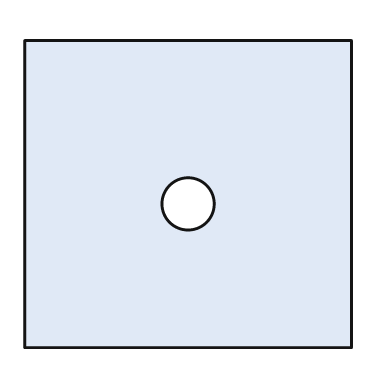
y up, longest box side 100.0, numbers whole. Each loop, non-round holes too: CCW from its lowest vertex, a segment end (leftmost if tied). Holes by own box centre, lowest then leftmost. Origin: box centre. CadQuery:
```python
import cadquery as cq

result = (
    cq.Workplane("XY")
    .moveTo(-50.0, -47.0)
    .lineTo(50.0, -47.0)
    .lineTo(50.0, 47.0)
    .lineTo(-50.0, 47.0)
    .close()
    .moveTo(0.0, -3.0)
    .circle(8.0)
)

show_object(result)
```